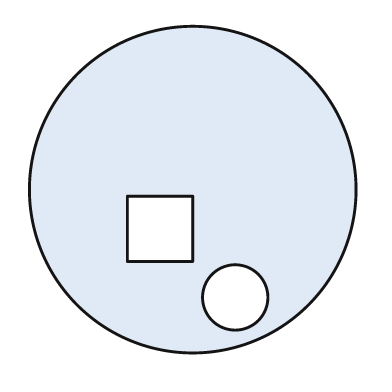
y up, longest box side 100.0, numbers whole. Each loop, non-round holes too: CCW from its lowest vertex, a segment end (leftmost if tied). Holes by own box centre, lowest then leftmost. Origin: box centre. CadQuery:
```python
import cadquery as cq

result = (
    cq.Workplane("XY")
    .moveTo(0.0, 0.0)
    .circle(50.0)
    .moveTo(13.0, -33.0)
    .circle(10.0)
    .moveTo(-20.0, -22.0)
    .lineTo(0.0, -22.0)
    .lineTo(0.0, -2.0)
    .lineTo(-20.0, -2.0)
    .close()
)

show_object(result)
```